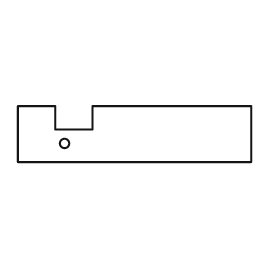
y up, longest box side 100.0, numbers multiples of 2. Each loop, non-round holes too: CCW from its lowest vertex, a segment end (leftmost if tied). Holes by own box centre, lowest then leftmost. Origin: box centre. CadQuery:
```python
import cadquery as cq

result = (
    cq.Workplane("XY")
    .moveTo(-50.0, -12.0)
    .lineTo(50.0, -12.0)
    .lineTo(50.0, 12.0)
    .lineTo(-18.0, 12.0)
    .lineTo(-18.0, 2.0)
    .lineTo(-34.0, 2.0)
    .lineTo(-34.0, 12.0)
    .lineTo(-50.0, 12.0)
    .close()
    .moveTo(-30.0, -4.0)
    .circle(2.0)
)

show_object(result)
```